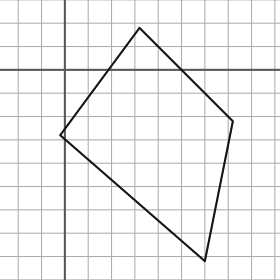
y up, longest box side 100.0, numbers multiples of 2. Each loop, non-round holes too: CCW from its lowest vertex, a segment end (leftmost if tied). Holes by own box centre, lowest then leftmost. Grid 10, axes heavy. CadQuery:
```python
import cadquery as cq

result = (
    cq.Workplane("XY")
    .moveTo(60.0, -82.0)
    .lineTo(72.0, -22.0)
    .lineTo(32.0, 18.0)
    .lineTo(-2.0, -28.0)
    .close()
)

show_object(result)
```